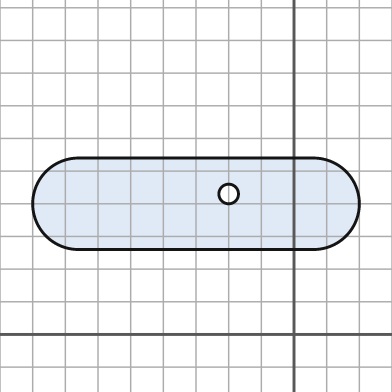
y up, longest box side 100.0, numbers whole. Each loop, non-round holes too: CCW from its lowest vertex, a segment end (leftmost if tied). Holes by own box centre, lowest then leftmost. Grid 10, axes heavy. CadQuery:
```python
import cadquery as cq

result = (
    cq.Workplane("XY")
    .moveTo(-66.0, 26.0)
    .lineTo(6.0, 26.0)
    .threePointArc((20.0, 40.0), (6.0, 54.0))
    .lineTo(-66.0, 54.0)
    .threePointArc((-80.0, 40.0), (-66.0, 26.0))
    .close()
    .moveTo(-20.0, 43.0)
    .circle(3.0)
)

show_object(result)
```